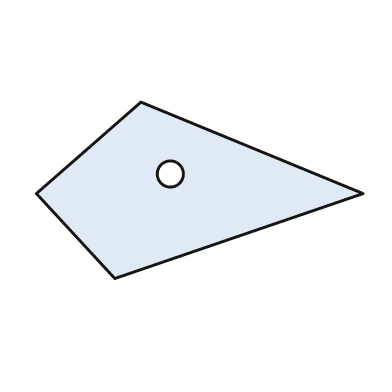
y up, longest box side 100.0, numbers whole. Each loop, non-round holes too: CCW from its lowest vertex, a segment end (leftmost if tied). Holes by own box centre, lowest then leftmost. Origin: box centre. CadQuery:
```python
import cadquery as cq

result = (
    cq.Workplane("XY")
    .moveTo(-26.0, -27.0)
    .lineTo(50.0, -1.0)
    .lineTo(-18.0, 27.0)
    .lineTo(-50.0, -1.0)
    .close()
    .moveTo(-9.0, 5.0)
    .circle(4.0)
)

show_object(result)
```